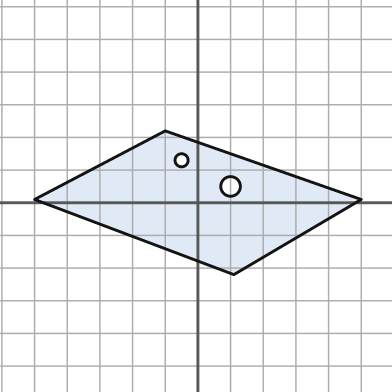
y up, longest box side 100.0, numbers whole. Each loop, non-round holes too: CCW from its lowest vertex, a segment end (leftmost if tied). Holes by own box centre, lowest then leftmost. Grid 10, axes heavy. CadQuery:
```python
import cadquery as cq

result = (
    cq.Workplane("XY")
    .moveTo(11.0, -22.0)
    .lineTo(50.0, 1.0)
    .lineTo(-10.0, 22.0)
    .lineTo(-50.0, 1.0)
    .close()
    .moveTo(10.0, 5.0)
    .circle(3.0)
    .moveTo(-5.0, 13.0)
    .circle(2.0)
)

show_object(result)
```